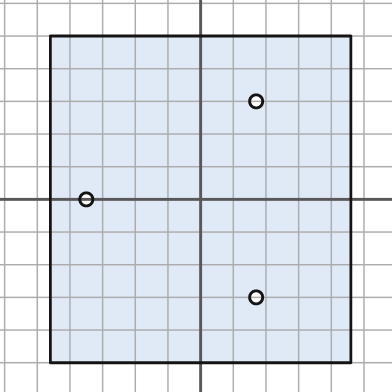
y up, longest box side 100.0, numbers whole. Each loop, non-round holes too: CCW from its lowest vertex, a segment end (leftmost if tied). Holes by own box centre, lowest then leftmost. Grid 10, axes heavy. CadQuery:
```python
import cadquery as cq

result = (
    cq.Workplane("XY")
    .moveTo(-46.0, -50.0)
    .lineTo(46.0, -50.0)
    .lineTo(46.0, 50.0)
    .lineTo(-46.0, 50.0)
    .close()
    .moveTo(17.0, -30.0)
    .circle(2.0)
    .moveTo(-35.0, 0.0)
    .circle(2.0)
    .moveTo(17.0, 30.0)
    .circle(2.0)
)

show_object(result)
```